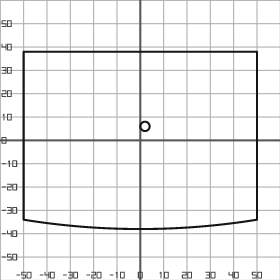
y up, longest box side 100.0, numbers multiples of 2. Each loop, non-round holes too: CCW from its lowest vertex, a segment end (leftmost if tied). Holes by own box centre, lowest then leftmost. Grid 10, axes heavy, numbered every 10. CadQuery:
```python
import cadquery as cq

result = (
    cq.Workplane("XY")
    .moveTo(-50.0, -34.0)
    .threePointArc((0.0, -38.0), (50.0, -34.0))
    .lineTo(50.0, 38.0)
    .lineTo(-50.0, 38.0)
    .close()
    .moveTo(2.0, 6.0)
    .circle(2.0)
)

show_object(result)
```